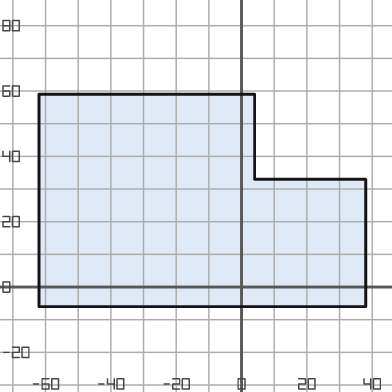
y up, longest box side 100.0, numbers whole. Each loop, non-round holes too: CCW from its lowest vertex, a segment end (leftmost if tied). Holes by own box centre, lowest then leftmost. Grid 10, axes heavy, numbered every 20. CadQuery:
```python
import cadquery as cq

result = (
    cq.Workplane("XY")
    .moveTo(-62.0, -6.0)
    .lineTo(38.0, -6.0)
    .lineTo(38.0, 33.0)
    .lineTo(4.0, 33.0)
    .lineTo(4.0, 59.0)
    .lineTo(-62.0, 59.0)
    .close()
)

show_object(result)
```